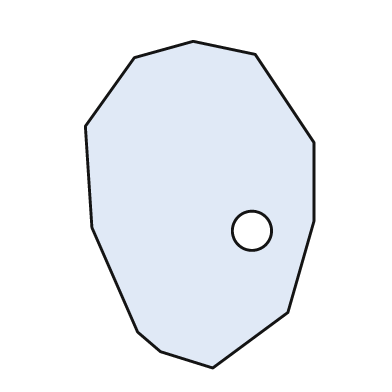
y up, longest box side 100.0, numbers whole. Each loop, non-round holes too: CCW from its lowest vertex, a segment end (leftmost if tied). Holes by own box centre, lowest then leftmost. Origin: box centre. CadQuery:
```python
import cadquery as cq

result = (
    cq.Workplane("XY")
    .moveTo(4.0, -50.0)
    .lineTo(27.0, -33.0)
    .lineTo(35.0, -5.0)
    .lineTo(35.0, 19.0)
    .lineTo(17.0, 46.0)
    .lineTo(-2.0, 50.0)
    .lineTo(-20.0, 45.0)
    .lineTo(-35.0, 24.0)
    .lineTo(-33.0, -7.0)
    .lineTo(-19.0, -39.0)
    .lineTo(-12.0, -45.0)
    .close()
    .moveTo(16.0, -8.0)
    .circle(6.0)
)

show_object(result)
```